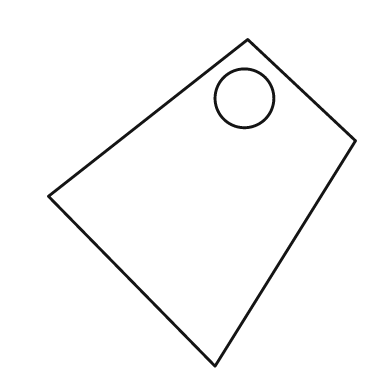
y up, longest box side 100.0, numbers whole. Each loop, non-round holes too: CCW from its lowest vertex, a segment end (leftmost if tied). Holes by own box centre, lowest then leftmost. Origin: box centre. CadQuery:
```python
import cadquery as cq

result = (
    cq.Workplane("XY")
    .moveTo(4.0, -50.0)
    .lineTo(47.0, 19.0)
    .lineTo(14.0, 50.0)
    .lineTo(-47.0, 2.0)
    .close()
    .moveTo(13.0, 32.0)
    .circle(9.0)
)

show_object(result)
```